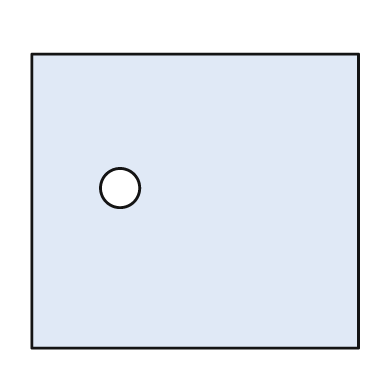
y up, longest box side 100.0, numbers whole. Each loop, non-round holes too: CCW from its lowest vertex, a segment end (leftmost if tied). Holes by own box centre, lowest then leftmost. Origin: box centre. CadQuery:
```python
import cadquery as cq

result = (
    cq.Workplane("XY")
    .moveTo(-50.0, -45.0)
    .lineTo(50.0, -45.0)
    .lineTo(50.0, 45.0)
    .lineTo(-50.0, 45.0)
    .close()
    .moveTo(-23.0, 4.0)
    .circle(6.0)
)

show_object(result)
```